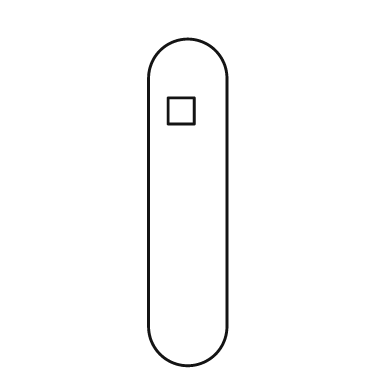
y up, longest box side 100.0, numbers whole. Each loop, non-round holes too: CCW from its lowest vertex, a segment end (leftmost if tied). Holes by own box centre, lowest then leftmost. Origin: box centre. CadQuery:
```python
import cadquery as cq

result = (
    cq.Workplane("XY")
    .moveTo(-12.0, -38.0)
    .threePointArc((0.0, -50.0), (12.0, -38.0))
    .lineTo(12.0, 38.0)
    .threePointArc((0.0, 50.0), (-12.0, 38.0))
    .close()
    .moveTo(-6.0, 24.0)
    .lineTo(2.0, 24.0)
    .lineTo(2.0, 32.0)
    .lineTo(-6.0, 32.0)
    .close()
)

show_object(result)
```